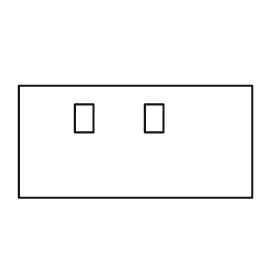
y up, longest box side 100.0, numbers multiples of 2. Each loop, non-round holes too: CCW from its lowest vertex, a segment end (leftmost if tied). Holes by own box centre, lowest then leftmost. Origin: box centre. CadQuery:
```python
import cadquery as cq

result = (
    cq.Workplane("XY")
    .moveTo(-50.0, -24.0)
    .lineTo(50.0, -24.0)
    .lineTo(50.0, 24.0)
    .lineTo(-50.0, 24.0)
    .close()
    .moveTo(-26.0, 4.0)
    .lineTo(-18.0, 4.0)
    .lineTo(-18.0, 16.0)
    .lineTo(-26.0, 16.0)
    .close()
    .moveTo(4.0, 4.0)
    .lineTo(12.0, 4.0)
    .lineTo(12.0, 16.0)
    .lineTo(4.0, 16.0)
    .close()
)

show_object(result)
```